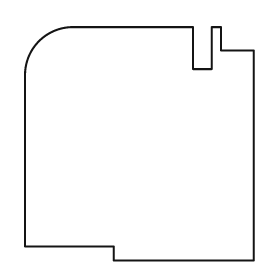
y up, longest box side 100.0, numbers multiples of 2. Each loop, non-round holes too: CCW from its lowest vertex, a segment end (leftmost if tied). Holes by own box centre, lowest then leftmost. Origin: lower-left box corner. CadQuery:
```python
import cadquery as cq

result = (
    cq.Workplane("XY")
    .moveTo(38.0, 0.0)
    .lineTo(98.0, 0.0)
    .lineTo(98.0, 90.0)
    .lineTo(84.0, 90.0)
    .lineTo(84.0, 100.0)
    .lineTo(80.0, 100.0)
    .lineTo(80.0, 82.0)
    .lineTo(72.0, 82.0)
    .lineTo(72.0, 100.0)
    .lineTo(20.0, 100.0)
    .threePointArc((6.0, 94.0), (0.0, 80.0))
    .lineTo(0.0, 6.0)
    .lineTo(38.0, 6.0)
    .close()
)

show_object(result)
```